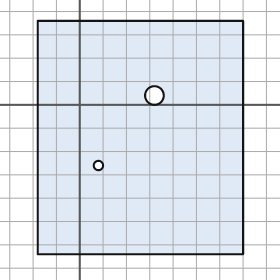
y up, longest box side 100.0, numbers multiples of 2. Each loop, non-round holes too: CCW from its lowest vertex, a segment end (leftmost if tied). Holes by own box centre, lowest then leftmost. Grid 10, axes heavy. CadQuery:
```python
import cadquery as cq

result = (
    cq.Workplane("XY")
    .moveTo(-18.0, -64.0)
    .lineTo(70.0, -64.0)
    .lineTo(70.0, 36.0)
    .lineTo(-18.0, 36.0)
    .close()
    .moveTo(8.0, -26.0)
    .circle(2.0)
    .moveTo(32.0, 4.0)
    .circle(4.0)
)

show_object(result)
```